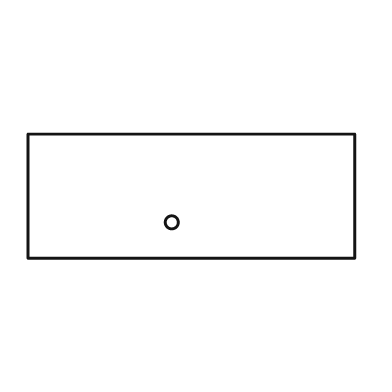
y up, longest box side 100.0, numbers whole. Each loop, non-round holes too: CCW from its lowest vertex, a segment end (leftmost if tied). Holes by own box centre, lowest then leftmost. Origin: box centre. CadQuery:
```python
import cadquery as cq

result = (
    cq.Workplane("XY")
    .moveTo(-50.0, -19.0)
    .lineTo(50.0, -19.0)
    .lineTo(50.0, 19.0)
    .lineTo(-50.0, 19.0)
    .close()
    .moveTo(-6.0, -8.0)
    .circle(2.0)
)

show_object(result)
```